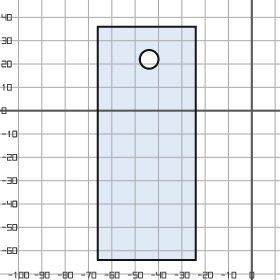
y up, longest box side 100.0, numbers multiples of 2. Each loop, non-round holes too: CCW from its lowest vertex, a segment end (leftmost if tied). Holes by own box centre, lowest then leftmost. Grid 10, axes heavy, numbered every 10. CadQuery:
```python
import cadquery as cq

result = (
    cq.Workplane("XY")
    .moveTo(-66.0, -64.0)
    .lineTo(-24.0, -64.0)
    .lineTo(-24.0, 36.0)
    .lineTo(-66.0, 36.0)
    .close()
    .moveTo(-44.0, 22.0)
    .circle(4.0)
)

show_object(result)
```